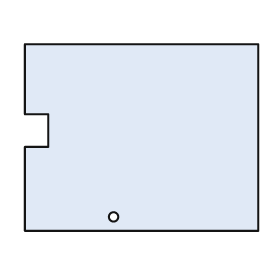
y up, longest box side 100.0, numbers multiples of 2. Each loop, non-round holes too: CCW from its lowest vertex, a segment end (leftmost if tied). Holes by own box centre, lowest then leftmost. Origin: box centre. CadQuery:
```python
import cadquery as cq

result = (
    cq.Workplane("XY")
    .moveTo(-50.0, -40.0)
    .lineTo(50.0, -40.0)
    .lineTo(50.0, 40.0)
    .lineTo(-50.0, 40.0)
    .lineTo(-50.0, 10.0)
    .lineTo(-40.0, 10.0)
    .lineTo(-40.0, -4.0)
    .lineTo(-50.0, -4.0)
    .close()
    .moveTo(-12.0, -34.0)
    .circle(2.0)
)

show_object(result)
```